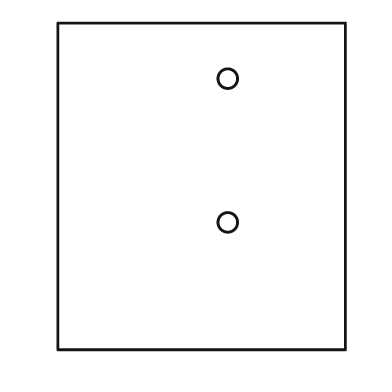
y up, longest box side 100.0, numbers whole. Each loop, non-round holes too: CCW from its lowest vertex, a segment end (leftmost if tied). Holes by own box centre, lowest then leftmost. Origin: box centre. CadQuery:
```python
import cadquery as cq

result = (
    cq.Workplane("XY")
    .moveTo(-44.0, -50.0)
    .lineTo(44.0, -50.0)
    .lineTo(44.0, 50.0)
    .lineTo(-44.0, 50.0)
    .close()
    .moveTo(8.0, -11.0)
    .circle(3.0)
    .moveTo(8.0, 33.0)
    .circle(3.0)
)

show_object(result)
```